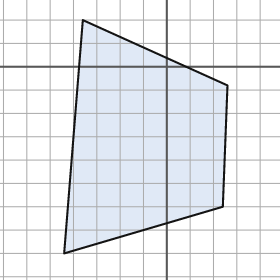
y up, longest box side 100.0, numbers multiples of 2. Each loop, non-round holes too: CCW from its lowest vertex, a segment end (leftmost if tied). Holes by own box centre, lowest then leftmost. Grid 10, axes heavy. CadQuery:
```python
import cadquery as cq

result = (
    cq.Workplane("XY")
    .moveTo(-44.0, -80.0)
    .lineTo(24.0, -60.0)
    .lineTo(26.0, -8.0)
    .lineTo(-36.0, 20.0)
    .close()
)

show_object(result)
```